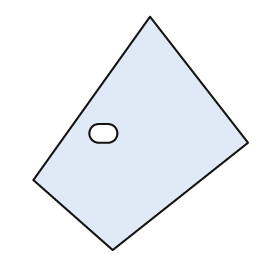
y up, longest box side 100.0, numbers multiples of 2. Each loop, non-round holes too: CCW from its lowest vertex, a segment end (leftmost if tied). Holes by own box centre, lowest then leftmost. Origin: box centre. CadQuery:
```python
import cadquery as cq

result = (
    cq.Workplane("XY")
    .moveTo(-12.0, -50.0)
    .lineTo(46.0, -4.0)
    .lineTo(4.0, 50.0)
    .lineTo(-46.0, -20.0)
    .close()
    .moveTo(-18.0, -4.0)
    .lineTo(-14.0, -4.0)
    .threePointArc((-10.0, 0.0), (-14.0, 4.0))
    .lineTo(-18.0, 4.0)
    .threePointArc((-22.0, 0.0), (-18.0, -4.0))
    .close()
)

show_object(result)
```